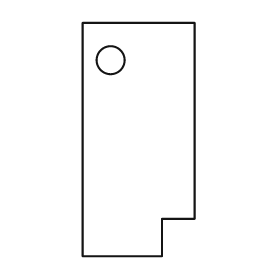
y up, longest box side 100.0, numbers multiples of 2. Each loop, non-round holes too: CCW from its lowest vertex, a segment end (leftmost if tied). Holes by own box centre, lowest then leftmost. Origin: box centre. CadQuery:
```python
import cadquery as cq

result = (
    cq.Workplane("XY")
    .moveTo(-24.0, -50.0)
    .lineTo(10.0, -50.0)
    .lineTo(10.0, -34.0)
    .lineTo(24.0, -34.0)
    .lineTo(24.0, 50.0)
    .lineTo(-24.0, 50.0)
    .close()
    .moveTo(-12.0, 34.0)
    .circle(6.0)
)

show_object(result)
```